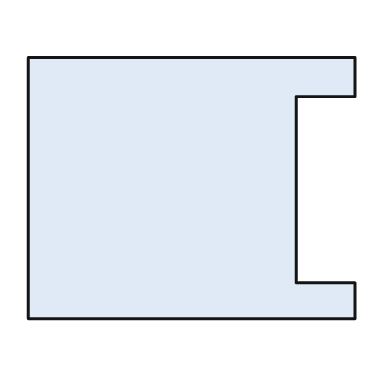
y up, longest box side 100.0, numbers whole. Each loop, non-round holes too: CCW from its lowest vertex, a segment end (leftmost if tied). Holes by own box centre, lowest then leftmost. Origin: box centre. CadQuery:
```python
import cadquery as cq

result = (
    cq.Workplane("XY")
    .moveTo(-50.0, -40.0)
    .lineTo(50.0, -40.0)
    .lineTo(50.0, -29.0)
    .lineTo(32.0, -29.0)
    .lineTo(32.0, 28.0)
    .lineTo(50.0, 28.0)
    .lineTo(50.0, 40.0)
    .lineTo(-50.0, 40.0)
    .close()
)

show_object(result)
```